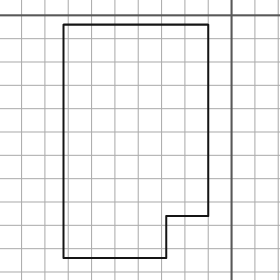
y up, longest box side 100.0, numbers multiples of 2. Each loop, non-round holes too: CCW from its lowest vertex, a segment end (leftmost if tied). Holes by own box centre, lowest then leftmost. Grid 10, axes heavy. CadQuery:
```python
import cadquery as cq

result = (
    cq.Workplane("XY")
    .moveTo(-72.0, -104.0)
    .lineTo(-28.0, -104.0)
    .lineTo(-28.0, -86.0)
    .lineTo(-10.0, -86.0)
    .lineTo(-10.0, -4.0)
    .lineTo(-72.0, -4.0)
    .close()
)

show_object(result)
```